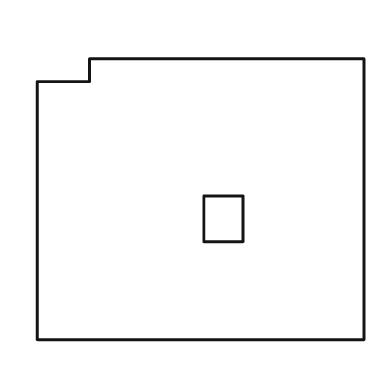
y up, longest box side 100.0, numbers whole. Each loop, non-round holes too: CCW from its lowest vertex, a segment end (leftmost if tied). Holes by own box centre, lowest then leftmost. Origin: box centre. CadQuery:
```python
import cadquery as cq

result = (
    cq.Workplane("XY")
    .moveTo(-50.0, -43.0)
    .lineTo(50.0, -43.0)
    .lineTo(50.0, 43.0)
    .lineTo(-34.0, 43.0)
    .lineTo(-34.0, 36.0)
    .lineTo(-50.0, 36.0)
    .close()
    .moveTo(1.0, -13.0)
    .lineTo(13.0, -13.0)
    .lineTo(13.0, 1.0)
    .lineTo(1.0, 1.0)
    .close()
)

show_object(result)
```